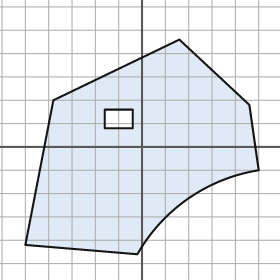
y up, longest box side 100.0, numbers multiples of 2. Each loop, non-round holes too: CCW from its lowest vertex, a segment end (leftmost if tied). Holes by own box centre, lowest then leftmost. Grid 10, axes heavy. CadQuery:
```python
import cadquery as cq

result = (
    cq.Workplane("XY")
    .moveTo(-2.0, -46.0)
    .threePointArc((20.0, -22.0), (50.0, -10.0))
    .lineTo(46.0, 18.0)
    .lineTo(16.0, 46.0)
    .lineTo(-38.0, 20.0)
    .lineTo(-50.0, -42.0)
    .close()
    .moveTo(-16.0, 8.0)
    .lineTo(-4.0, 8.0)
    .lineTo(-4.0, 16.0)
    .lineTo(-16.0, 16.0)
    .close()
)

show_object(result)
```